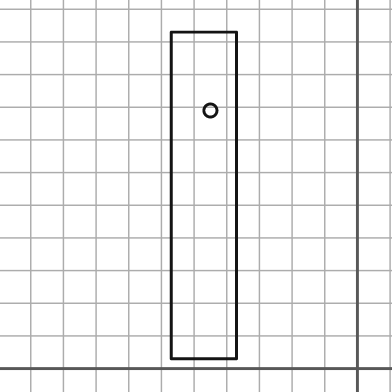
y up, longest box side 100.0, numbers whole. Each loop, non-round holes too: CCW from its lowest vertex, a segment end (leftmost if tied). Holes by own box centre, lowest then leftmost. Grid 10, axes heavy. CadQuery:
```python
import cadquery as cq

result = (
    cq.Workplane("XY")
    .moveTo(-57.0, 3.0)
    .lineTo(-37.0, 3.0)
    .lineTo(-37.0, 103.0)
    .lineTo(-57.0, 103.0)
    .close()
    .moveTo(-45.0, 79.0)
    .circle(2.0)
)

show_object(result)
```